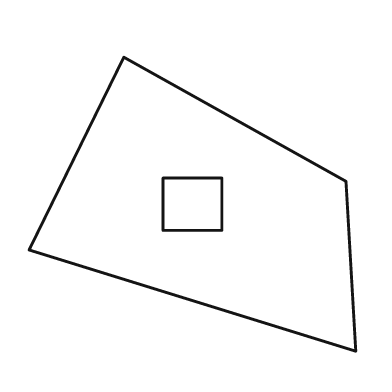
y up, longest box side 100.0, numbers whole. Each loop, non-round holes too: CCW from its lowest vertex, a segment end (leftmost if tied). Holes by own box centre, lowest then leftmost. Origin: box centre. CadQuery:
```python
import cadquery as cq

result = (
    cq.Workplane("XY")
    .moveTo(50.0, -45.0)
    .lineTo(47.0, 7.0)
    .lineTo(-21.0, 45.0)
    .lineTo(-50.0, -14.0)
    .close()
    .moveTo(-9.0, -8.0)
    .lineTo(9.0, -8.0)
    .lineTo(9.0, 8.0)
    .lineTo(-9.0, 8.0)
    .close()
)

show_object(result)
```